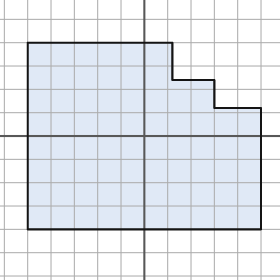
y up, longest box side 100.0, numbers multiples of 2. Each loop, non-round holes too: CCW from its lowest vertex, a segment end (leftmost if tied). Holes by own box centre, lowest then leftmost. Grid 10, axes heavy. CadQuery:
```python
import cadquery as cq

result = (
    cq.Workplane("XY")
    .moveTo(-50.0, -40.0)
    .lineTo(50.0, -40.0)
    .lineTo(50.0, 12.0)
    .lineTo(30.0, 12.0)
    .lineTo(30.0, 24.0)
    .lineTo(12.0, 24.0)
    .lineTo(12.0, 40.0)
    .lineTo(-50.0, 40.0)
    .close()
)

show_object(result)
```